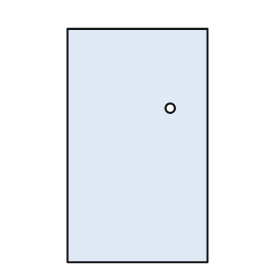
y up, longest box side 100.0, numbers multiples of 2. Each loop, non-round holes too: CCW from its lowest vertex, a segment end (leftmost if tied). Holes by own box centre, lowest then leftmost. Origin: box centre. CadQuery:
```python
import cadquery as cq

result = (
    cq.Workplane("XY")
    .moveTo(-30.0, -50.0)
    .lineTo(30.0, -50.0)
    .lineTo(30.0, 50.0)
    .lineTo(-30.0, 50.0)
    .close()
    .moveTo(14.0, 16.0)
    .circle(2.0)
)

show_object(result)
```